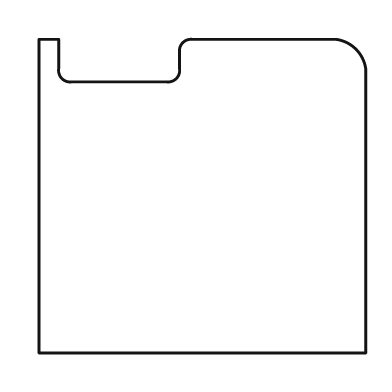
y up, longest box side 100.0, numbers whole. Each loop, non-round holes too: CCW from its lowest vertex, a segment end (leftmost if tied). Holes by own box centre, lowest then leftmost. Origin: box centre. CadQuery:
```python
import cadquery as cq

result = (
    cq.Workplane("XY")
    .moveTo(-50.0, -48.0)
    .lineTo(50.0, -48.0)
    .lineTo(50.0, 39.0)
    .threePointArc((47.0, 45.0), (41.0, 48.0))
    .lineTo(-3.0, 48.0)
    .threePointArc((-6.0, 47.0), (-7.0, 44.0))
    .lineTo(-7.0, 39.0)
    .threePointArc((-8.0, 36.0), (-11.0, 35.0))
    .lineTo(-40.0, 35.0)
    .threePointArc((-43.0, 36.0), (-44.0, 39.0))
    .lineTo(-44.0, 48.0)
    .lineTo(-50.0, 48.0)
    .close()
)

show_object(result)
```